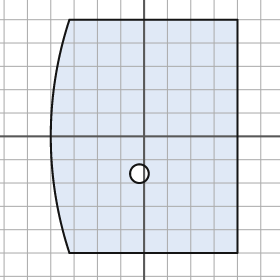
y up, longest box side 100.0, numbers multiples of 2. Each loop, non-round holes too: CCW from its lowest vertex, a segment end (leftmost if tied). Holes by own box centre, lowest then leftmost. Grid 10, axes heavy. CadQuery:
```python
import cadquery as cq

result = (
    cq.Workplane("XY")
    .moveTo(-32.0, -50.0)
    .lineTo(40.0, -50.0)
    .lineTo(40.0, 50.0)
    .lineTo(-32.0, 50.0)
    .threePointArc((-40.0, 0.0), (-32.0, -50.0))
    .close()
    .moveTo(-2.0, -16.0)
    .circle(4.0)
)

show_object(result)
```